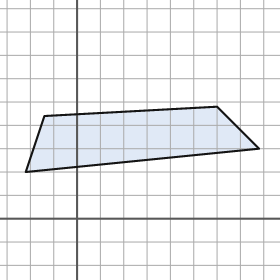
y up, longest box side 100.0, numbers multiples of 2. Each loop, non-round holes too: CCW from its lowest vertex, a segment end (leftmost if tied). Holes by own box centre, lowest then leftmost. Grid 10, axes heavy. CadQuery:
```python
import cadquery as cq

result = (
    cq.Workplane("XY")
    .moveTo(-22.0, 20.0)
    .lineTo(78.0, 30.0)
    .lineTo(60.0, 48.0)
    .lineTo(-14.0, 44.0)
    .close()
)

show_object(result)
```